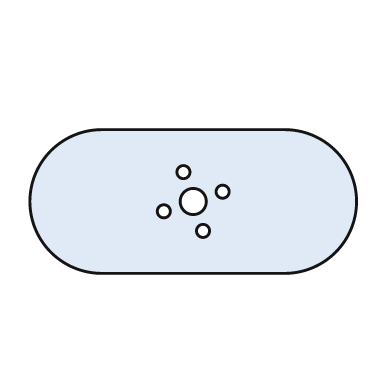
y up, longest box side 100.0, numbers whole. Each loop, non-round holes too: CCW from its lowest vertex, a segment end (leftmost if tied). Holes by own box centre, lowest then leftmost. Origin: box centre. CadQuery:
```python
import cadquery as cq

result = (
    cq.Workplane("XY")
    .moveTo(-28.0, -22.0)
    .lineTo(28.0, -22.0)
    .threePointArc((50.0, 0.0), (28.0, 22.0))
    .lineTo(-28.0, 22.0)
    .threePointArc((-50.0, 0.0), (-28.0, -22.0))
    .close()
    .moveTo(3.0, -9.0)
    .circle(2.0)
    .moveTo(-9.0, -3.0)
    .circle(2.0)
    .moveTo(0.0, 0.0)
    .circle(4.0)
    .moveTo(9.0, 3.0)
    .circle(2.0)
    .moveTo(-3.0, 9.0)
    .circle(2.0)
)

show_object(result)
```